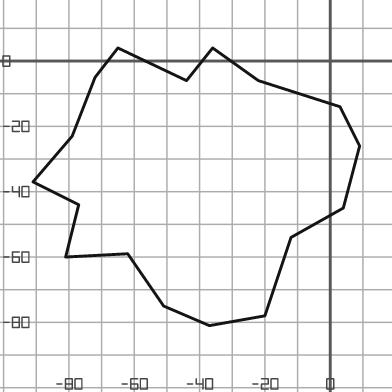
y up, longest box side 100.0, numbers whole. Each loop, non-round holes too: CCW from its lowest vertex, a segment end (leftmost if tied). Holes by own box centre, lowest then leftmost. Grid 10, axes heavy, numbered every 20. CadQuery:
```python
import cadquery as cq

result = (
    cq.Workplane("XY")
    .moveTo(-37.0, -81.0)
    .lineTo(-20.0, -78.0)
    .lineTo(-12.0, -54.0)
    .lineTo(4.0, -45.0)
    .lineTo(9.0, -26.0)
    .lineTo(3.0, -14.0)
    .lineTo(-22.0, -6.0)
    .lineTo(-36.0, 4.0)
    .lineTo(-44.0, -6.0)
    .lineTo(-65.0, 4.0)
    .lineTo(-72.0, -5.0)
    .lineTo(-79.0, -23.0)
    .lineTo(-91.0, -37.0)
    .lineTo(-77.0, -44.0)
    .lineTo(-81.0, -60.0)
    .lineTo(-62.0, -59.0)
    .lineTo(-51.0, -75.0)
    .close()
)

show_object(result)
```